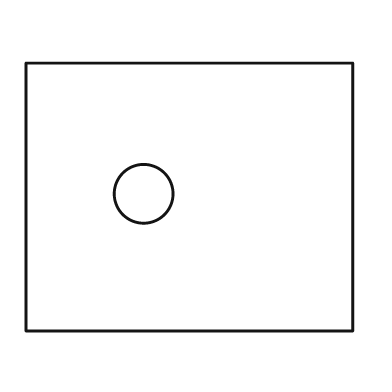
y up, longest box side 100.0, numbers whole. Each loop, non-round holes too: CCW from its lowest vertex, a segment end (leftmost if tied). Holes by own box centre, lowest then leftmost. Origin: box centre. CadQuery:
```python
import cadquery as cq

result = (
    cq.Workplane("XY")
    .moveTo(-50.0, -41.0)
    .lineTo(50.0, -41.0)
    .lineTo(50.0, 41.0)
    .lineTo(-50.0, 41.0)
    .close()
    .moveTo(-14.0, 1.0)
    .circle(9.0)
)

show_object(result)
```